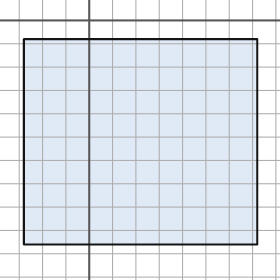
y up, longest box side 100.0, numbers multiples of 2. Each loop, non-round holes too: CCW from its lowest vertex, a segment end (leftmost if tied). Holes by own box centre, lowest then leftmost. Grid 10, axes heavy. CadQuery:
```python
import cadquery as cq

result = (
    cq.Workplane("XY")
    .moveTo(-28.0, -96.0)
    .lineTo(72.0, -96.0)
    .lineTo(72.0, -8.0)
    .lineTo(-28.0, -8.0)
    .close()
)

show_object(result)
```